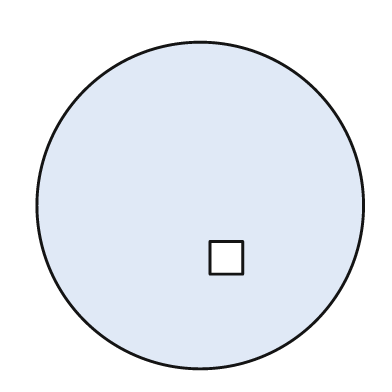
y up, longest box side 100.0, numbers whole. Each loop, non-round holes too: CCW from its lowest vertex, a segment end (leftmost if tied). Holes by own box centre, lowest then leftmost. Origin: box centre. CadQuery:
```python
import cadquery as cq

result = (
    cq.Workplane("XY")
    .moveTo(0.0, 0.0)
    .circle(50.0)
    .moveTo(3.0, -21.0)
    .lineTo(13.0, -21.0)
    .lineTo(13.0, -11.0)
    .lineTo(3.0, -11.0)
    .close()
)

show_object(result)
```